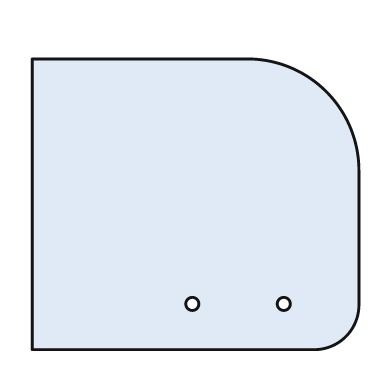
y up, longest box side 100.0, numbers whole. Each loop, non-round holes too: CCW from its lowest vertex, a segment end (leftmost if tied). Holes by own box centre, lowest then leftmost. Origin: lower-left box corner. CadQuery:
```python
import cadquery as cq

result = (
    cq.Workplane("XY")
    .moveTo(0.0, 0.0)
    .lineTo(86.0, 0.0)
    .threePointArc((96.0, 4.0), (100.0, 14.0))
    .lineTo(100.0, 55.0)
    .threePointArc((90.0, 79.0), (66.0, 89.0))
    .lineTo(0.0, 89.0)
    .close()
    .moveTo(49.0, 14.0)
    .circle(2.0)
    .moveTo(77.0, 14.0)
    .circle(2.0)
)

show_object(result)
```